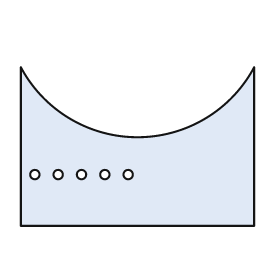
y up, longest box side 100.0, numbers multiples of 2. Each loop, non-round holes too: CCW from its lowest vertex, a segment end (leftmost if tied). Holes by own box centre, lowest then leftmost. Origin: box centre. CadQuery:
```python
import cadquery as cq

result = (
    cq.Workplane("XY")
    .moveTo(-50.0, -34.0)
    .lineTo(50.0, -34.0)
    .lineTo(50.0, 34.0)
    .threePointArc((0.0, 4.0), (-50.0, 34.0))
    .close()
    .moveTo(-44.0, -12.0)
    .circle(2.0)
    .moveTo(-34.0, -12.0)
    .circle(2.0)
    .moveTo(-24.0, -12.0)
    .circle(2.0)
    .moveTo(-14.0, -12.0)
    .circle(2.0)
    .moveTo(-4.0, -12.0)
    .circle(2.0)
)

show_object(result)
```